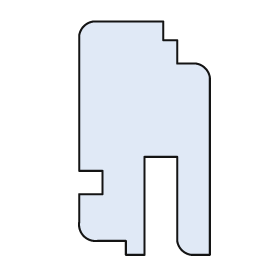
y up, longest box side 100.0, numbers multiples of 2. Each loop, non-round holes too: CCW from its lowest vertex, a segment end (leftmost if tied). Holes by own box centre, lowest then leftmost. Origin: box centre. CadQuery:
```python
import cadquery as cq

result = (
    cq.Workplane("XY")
    .moveTo(-8.0, -50.0)
    .lineTo(0.0, -50.0)
    .lineTo(0.0, -8.0)
    .lineTo(14.0, -8.0)
    .lineTo(14.0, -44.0)
    .threePointArc((16.0, -48.0), (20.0, -50.0))
    .lineTo(28.0, -50.0)
    .lineTo(28.0, 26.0)
    .threePointArc((26.0, 30.0), (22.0, 32.0))
    .lineTo(14.0, 32.0)
    .lineTo(14.0, 42.0)
    .lineTo(8.0, 42.0)
    .lineTo(8.0, 50.0)
    .lineTo(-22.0, 50.0)
    .threePointArc((-26.0, 48.0), (-28.0, 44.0))
    .lineTo(-28.0, -14.0)
    .lineTo(-18.0, -14.0)
    .lineTo(-18.0, -24.0)
    .lineTo(-28.0, -24.0)
    .lineTo(-28.0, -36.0)
    .threePointArc((-26.0, -42.0), (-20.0, -44.0))
    .lineTo(-8.0, -44.0)
    .close()
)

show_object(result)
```